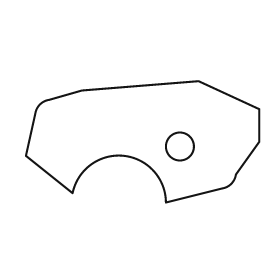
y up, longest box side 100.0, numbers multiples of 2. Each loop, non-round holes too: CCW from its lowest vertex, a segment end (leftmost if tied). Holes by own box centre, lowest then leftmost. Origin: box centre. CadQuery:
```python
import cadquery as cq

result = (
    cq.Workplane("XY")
    .moveTo(10.0, -26.0)
    .lineTo(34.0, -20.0)
    .threePointArc((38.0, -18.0), (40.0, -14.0))
    .lineTo(50.0, 0.0)
    .lineTo(50.0, 14.0)
    .lineTo(24.0, 26.0)
    .lineTo(-26.0, 22.0)
    .lineTo(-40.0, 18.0)
    .threePointArc((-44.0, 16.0), (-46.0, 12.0))
    .lineTo(-50.0, -6.0)
    .lineTo(-30.0, -22.0)
    .threePointArc((-8.0, -6.0), (10.0, -26.0))
    .close()
    .moveTo(16.0, -2.0)
    .circle(6.0)
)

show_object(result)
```